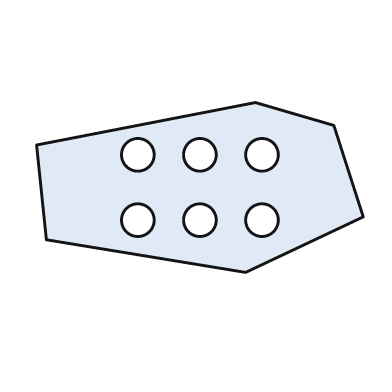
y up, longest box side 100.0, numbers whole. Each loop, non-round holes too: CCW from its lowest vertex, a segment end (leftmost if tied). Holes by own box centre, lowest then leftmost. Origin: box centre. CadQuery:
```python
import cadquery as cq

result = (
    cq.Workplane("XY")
    .moveTo(14.0, -26.0)
    .lineTo(50.0, -9.0)
    .lineTo(41.0, 19.0)
    .lineTo(17.0, 26.0)
    .lineTo(-50.0, 13.0)
    .lineTo(-47.0, -16.0)
    .close()
    .moveTo(-19.0, -10.0)
    .circle(5.0)
    .moveTo(0.0, -10.0)
    .circle(5.0)
    .moveTo(19.0, -10.0)
    .circle(5.0)
    .moveTo(-19.0, 10.0)
    .circle(5.0)
    .moveTo(0.0, 10.0)
    .circle(5.0)
    .moveTo(19.0, 10.0)
    .circle(5.0)
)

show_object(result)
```